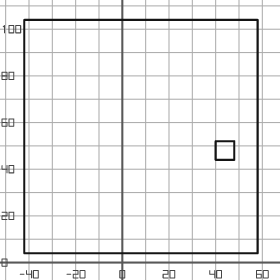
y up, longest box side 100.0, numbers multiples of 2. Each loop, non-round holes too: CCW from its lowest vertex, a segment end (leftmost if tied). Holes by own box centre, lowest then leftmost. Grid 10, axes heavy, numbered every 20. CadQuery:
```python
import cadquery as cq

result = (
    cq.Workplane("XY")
    .moveTo(-42.0, 4.0)
    .lineTo(58.0, 4.0)
    .lineTo(58.0, 104.0)
    .lineTo(-42.0, 104.0)
    .close()
    .moveTo(40.0, 44.0)
    .lineTo(48.0, 44.0)
    .lineTo(48.0, 52.0)
    .lineTo(40.0, 52.0)
    .close()
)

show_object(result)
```